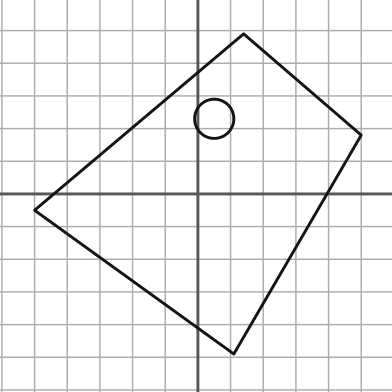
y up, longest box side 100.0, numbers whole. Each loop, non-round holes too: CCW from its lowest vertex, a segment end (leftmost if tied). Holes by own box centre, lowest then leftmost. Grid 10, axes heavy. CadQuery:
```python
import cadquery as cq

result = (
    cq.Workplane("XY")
    .moveTo(11.0, -49.0)
    .lineTo(50.0, 18.0)
    .lineTo(14.0, 49.0)
    .lineTo(-50.0, -5.0)
    .close()
    .moveTo(5.0, 23.0)
    .circle(6.0)
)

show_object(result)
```